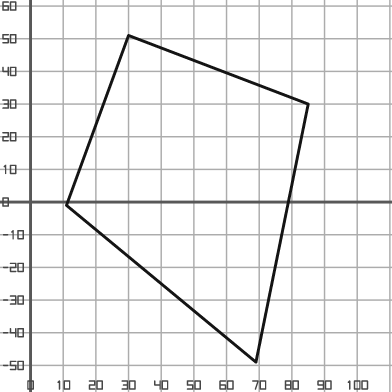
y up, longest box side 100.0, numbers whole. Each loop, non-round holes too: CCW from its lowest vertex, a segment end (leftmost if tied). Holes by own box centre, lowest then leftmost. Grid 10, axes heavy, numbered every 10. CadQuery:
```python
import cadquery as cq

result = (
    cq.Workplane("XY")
    .moveTo(69.0, -49.0)
    .lineTo(85.0, 30.0)
    .lineTo(30.0, 51.0)
    .lineTo(11.0, -1.0)
    .close()
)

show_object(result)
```